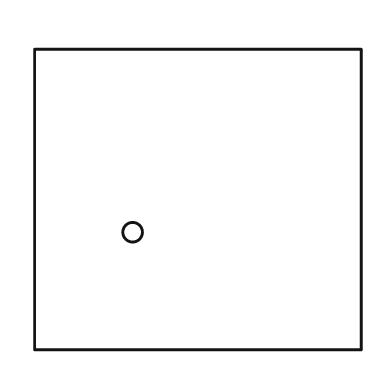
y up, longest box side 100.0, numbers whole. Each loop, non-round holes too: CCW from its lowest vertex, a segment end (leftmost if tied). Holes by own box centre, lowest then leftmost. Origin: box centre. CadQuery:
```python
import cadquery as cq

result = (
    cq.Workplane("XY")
    .moveTo(-50.0, -46.0)
    .lineTo(50.0, -46.0)
    .lineTo(50.0, 46.0)
    .lineTo(-50.0, 46.0)
    .close()
    .moveTo(-20.0, -10.0)
    .circle(3.0)
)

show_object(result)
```